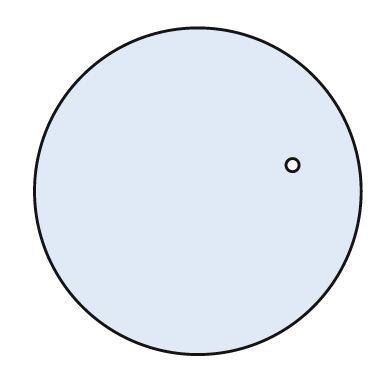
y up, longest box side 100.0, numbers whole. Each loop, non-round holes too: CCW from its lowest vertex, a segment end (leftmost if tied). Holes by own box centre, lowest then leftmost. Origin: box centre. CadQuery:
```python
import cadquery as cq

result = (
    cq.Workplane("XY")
    .moveTo(0.0, 0.0)
    .circle(50.0)
    .moveTo(29.0, 8.0)
    .circle(2.0)
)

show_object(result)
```